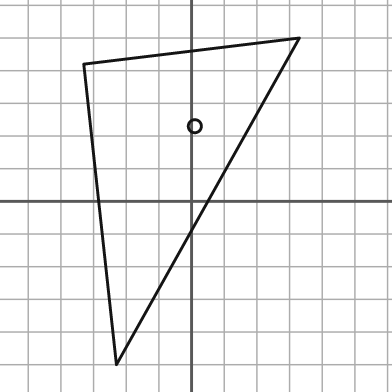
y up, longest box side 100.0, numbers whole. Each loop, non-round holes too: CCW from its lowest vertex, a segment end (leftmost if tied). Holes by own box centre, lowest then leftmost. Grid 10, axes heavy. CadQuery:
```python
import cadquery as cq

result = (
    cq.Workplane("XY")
    .moveTo(-23.0, -50.0)
    .lineTo(33.0, 50.0)
    .lineTo(-33.0, 42.0)
    .close()
    .moveTo(1.0, 23.0)
    .circle(2.0)
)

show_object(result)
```